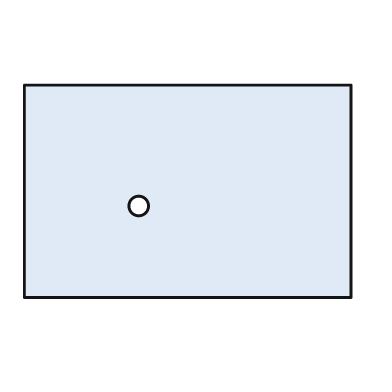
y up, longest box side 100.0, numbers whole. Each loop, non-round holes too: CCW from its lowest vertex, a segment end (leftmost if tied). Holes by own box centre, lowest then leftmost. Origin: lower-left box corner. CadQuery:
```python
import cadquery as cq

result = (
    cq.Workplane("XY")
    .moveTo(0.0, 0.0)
    .lineTo(100.0, 0.0)
    .lineTo(100.0, 65.0)
    .lineTo(0.0, 65.0)
    .close()
    .moveTo(35.0, 28.0)
    .circle(3.0)
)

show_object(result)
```